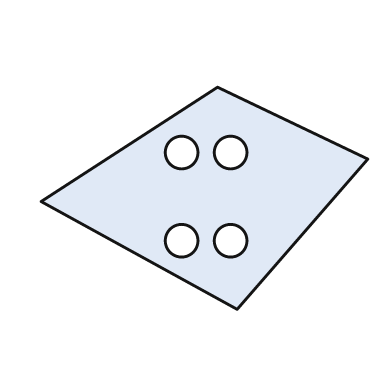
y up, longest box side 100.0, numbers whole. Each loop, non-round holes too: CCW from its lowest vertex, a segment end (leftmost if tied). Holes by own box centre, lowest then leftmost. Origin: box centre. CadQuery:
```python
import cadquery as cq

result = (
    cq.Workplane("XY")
    .moveTo(10.0, -34.0)
    .lineTo(50.0, 12.0)
    .lineTo(4.0, 34.0)
    .lineTo(-50.0, -1.0)
    .close()
    .moveTo(-7.0, -13.0)
    .circle(5.0)
    .moveTo(8.0, -13.0)
    .circle(5.0)
    .moveTo(-7.0, 14.0)
    .circle(5.0)
    .moveTo(8.0, 14.0)
    .circle(5.0)
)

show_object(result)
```